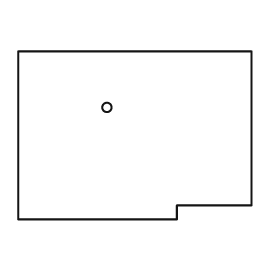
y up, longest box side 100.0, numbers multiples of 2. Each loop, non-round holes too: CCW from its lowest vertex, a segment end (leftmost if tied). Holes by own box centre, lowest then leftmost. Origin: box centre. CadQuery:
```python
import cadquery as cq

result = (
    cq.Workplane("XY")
    .moveTo(-50.0, -36.0)
    .lineTo(18.0, -36.0)
    .lineTo(18.0, -30.0)
    .lineTo(50.0, -30.0)
    .lineTo(50.0, 36.0)
    .lineTo(-50.0, 36.0)
    .close()
    .moveTo(-12.0, 12.0)
    .circle(2.0)
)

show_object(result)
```